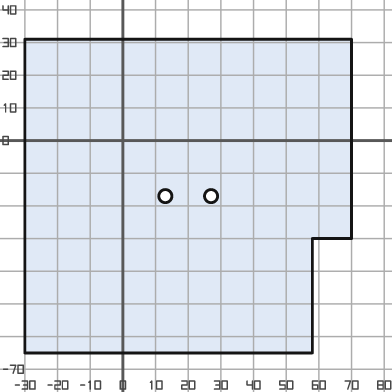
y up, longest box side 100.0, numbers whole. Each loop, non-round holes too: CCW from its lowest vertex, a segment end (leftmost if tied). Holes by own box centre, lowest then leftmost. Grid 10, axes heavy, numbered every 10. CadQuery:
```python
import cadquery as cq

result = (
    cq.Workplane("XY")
    .moveTo(-30.0, -65.0)
    .lineTo(58.0, -65.0)
    .lineTo(58.0, -30.0)
    .lineTo(70.0, -30.0)
    .lineTo(70.0, 31.0)
    .lineTo(-30.0, 31.0)
    .close()
    .moveTo(13.0, -17.0)
    .circle(2.0)
    .moveTo(27.0, -17.0)
    .circle(2.0)
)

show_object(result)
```